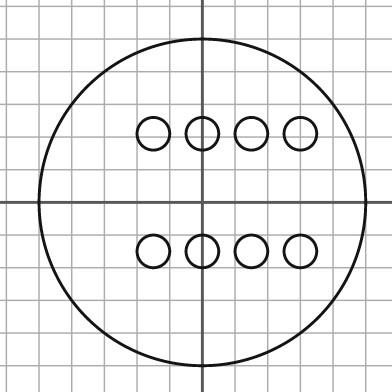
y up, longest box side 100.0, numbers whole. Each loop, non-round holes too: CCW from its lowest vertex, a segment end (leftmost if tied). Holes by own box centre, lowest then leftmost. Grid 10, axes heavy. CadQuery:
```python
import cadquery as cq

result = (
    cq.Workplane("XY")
    .moveTo(0.0, 0.0)
    .circle(50.0)
    .moveTo(-15.0, -15.0)
    .circle(5.0)
    .moveTo(0.0, -15.0)
    .circle(5.0)
    .moveTo(15.0, -15.0)
    .circle(5.0)
    .moveTo(30.0, -15.0)
    .circle(5.0)
    .moveTo(-15.0, 21.0)
    .circle(5.0)
    .moveTo(0.0, 21.0)
    .circle(5.0)
    .moveTo(15.0, 21.0)
    .circle(5.0)
    .moveTo(30.0, 21.0)
    .circle(5.0)
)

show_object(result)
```